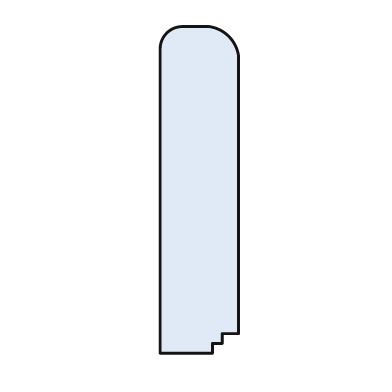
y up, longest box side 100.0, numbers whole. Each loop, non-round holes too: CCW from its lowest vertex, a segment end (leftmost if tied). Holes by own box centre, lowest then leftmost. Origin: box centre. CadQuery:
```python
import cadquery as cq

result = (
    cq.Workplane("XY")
    .moveTo(-12.0, -50.0)
    .lineTo(4.0, -50.0)
    .lineTo(4.0, -47.0)
    .lineTo(7.0, -47.0)
    .lineTo(7.0, -44.0)
    .lineTo(12.0, -44.0)
    .lineTo(12.0, 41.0)
    .threePointArc((9.0, 47.0), (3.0, 50.0))
    .lineTo(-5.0, 50.0)
    .threePointArc((-10.0, 48.0), (-12.0, 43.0))
    .close()
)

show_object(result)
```